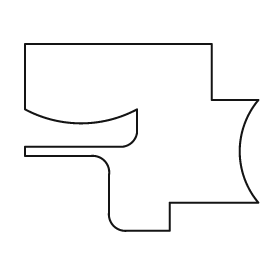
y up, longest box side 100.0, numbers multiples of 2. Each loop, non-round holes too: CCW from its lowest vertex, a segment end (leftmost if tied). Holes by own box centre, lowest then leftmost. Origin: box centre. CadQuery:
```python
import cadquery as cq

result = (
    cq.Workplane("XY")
    .moveTo(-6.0, -40.0)
    .lineTo(12.0, -40.0)
    .lineTo(12.0, -28.0)
    .lineTo(50.0, -28.0)
    .threePointArc((42.0, -6.0), (50.0, 16.0))
    .lineTo(30.0, 16.0)
    .lineTo(30.0, 40.0)
    .lineTo(-50.0, 40.0)
    .lineTo(-50.0, 12.0)
    .threePointArc((-26.0, 6.0), (-2.0, 12.0))
    .lineTo(-2.0, 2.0)
    .threePointArc((-4.0, -2.0), (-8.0, -4.0))
    .lineTo(-50.0, -4.0)
    .lineTo(-50.0, -8.0)
    .lineTo(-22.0, -8.0)
    .threePointArc((-16.0, -10.0), (-14.0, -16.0))
    .lineTo(-14.0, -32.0)
    .threePointArc((-12.0, -38.0), (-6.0, -40.0))
    .close()
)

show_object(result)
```